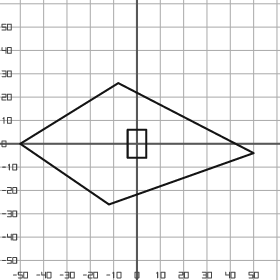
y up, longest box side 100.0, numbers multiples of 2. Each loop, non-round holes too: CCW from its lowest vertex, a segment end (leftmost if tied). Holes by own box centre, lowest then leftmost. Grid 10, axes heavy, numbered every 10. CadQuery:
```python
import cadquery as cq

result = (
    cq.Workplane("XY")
    .moveTo(-12.0, -26.0)
    .lineTo(50.0, -4.0)
    .lineTo(-8.0, 26.0)
    .lineTo(-50.0, 0.0)
    .close()
    .moveTo(-4.0, -6.0)
    .lineTo(4.0, -6.0)
    .lineTo(4.0, 6.0)
    .lineTo(-4.0, 6.0)
    .close()
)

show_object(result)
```